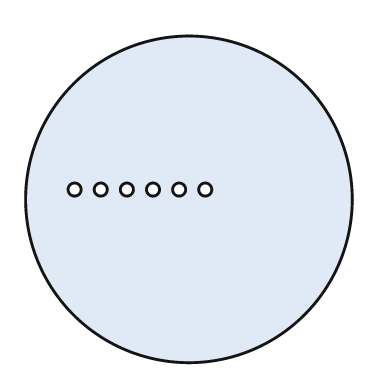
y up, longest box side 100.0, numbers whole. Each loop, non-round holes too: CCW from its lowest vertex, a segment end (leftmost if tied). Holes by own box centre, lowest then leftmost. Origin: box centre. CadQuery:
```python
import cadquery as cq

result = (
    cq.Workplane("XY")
    .moveTo(0.0, 0.0)
    .circle(50.0)
    .moveTo(-35.0, 3.0)
    .circle(2.0)
    .moveTo(-27.0, 3.0)
    .circle(2.0)
    .moveTo(-19.0, 3.0)
    .circle(2.0)
    .moveTo(-11.0, 3.0)
    .circle(2.0)
    .moveTo(-3.0, 3.0)
    .circle(2.0)
    .moveTo(5.0, 3.0)
    .circle(2.0)
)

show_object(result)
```